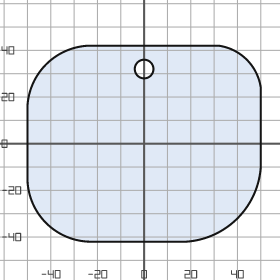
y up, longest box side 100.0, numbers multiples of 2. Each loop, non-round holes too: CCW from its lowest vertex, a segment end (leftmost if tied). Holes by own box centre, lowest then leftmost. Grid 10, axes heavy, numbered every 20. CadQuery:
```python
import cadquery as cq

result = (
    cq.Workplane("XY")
    .moveTo(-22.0, -42.0)
    .lineTo(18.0, -42.0)
    .threePointArc((40.0, -32.0), (50.0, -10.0))
    .lineTo(50.0, 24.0)
    .threePointArc((44.0, 36.0), (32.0, 42.0))
    .lineTo(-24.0, 42.0)
    .threePointArc((-42.0, 34.0), (-50.0, 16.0))
    .lineTo(-50.0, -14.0)
    .threePointArc((-42.0, -34.0), (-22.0, -42.0))
    .close()
    .moveTo(0.0, 32.0)
    .circle(4.0)
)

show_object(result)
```